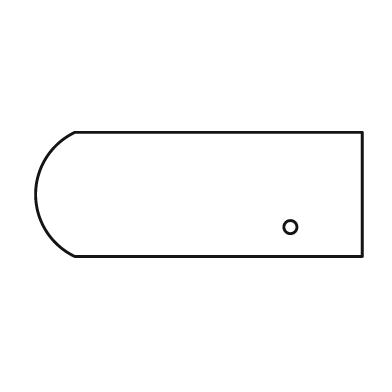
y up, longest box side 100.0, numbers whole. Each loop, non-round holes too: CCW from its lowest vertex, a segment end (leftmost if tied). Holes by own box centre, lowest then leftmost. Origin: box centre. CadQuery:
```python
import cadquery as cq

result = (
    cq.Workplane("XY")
    .moveTo(-38.0, -19.0)
    .lineTo(50.0, -19.0)
    .lineTo(50.0, 19.0)
    .lineTo(-38.0, 19.0)
    .threePointArc((-50.0, 0.0), (-38.0, -19.0))
    .close()
    .moveTo(28.0, -10.0)
    .circle(2.0)
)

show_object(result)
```